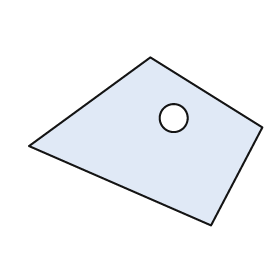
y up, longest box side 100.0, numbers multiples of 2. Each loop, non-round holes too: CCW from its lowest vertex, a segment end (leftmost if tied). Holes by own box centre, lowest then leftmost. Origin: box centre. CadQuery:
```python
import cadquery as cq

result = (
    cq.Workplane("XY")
    .moveTo(28.0, -36.0)
    .lineTo(50.0, 6.0)
    .lineTo(2.0, 36.0)
    .lineTo(-50.0, -2.0)
    .close()
    .moveTo(12.0, 10.0)
    .circle(6.0)
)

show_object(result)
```